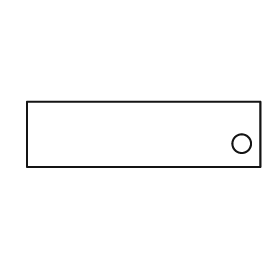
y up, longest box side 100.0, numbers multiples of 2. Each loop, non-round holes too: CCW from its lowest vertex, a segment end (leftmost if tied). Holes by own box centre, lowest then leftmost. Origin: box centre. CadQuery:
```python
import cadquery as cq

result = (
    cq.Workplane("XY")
    .moveTo(-50.0, -14.0)
    .lineTo(50.0, -14.0)
    .lineTo(50.0, 14.0)
    .lineTo(-50.0, 14.0)
    .close()
    .moveTo(42.0, -4.0)
    .circle(4.0)
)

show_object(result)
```